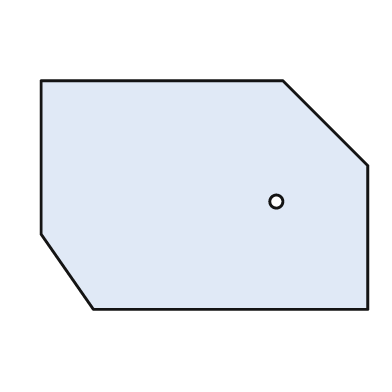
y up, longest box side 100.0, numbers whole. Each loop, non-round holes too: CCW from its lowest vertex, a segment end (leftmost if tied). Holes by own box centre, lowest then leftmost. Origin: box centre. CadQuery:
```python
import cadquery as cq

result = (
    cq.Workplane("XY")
    .moveTo(-34.0, -35.0)
    .lineTo(50.0, -35.0)
    .lineTo(50.0, 9.0)
    .lineTo(24.0, 35.0)
    .lineTo(-50.0, 35.0)
    .lineTo(-50.0, -12.0)
    .close()
    .moveTo(22.0, -2.0)
    .circle(2.0)
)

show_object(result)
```